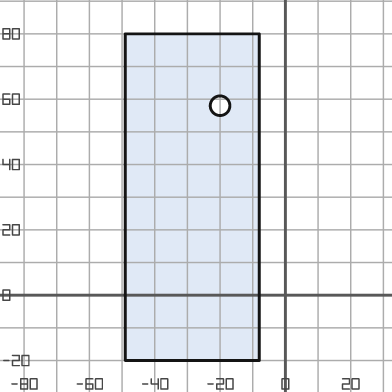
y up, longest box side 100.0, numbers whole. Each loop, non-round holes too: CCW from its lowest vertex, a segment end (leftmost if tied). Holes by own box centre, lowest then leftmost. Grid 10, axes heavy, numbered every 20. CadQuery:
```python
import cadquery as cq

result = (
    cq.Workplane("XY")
    .moveTo(-49.0, -20.0)
    .lineTo(-8.0, -20.0)
    .lineTo(-8.0, 80.0)
    .lineTo(-49.0, 80.0)
    .close()
    .moveTo(-20.0, 58.0)
    .circle(3.0)
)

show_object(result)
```